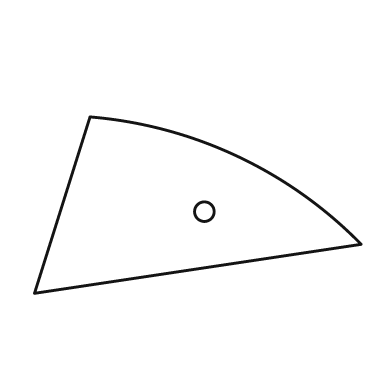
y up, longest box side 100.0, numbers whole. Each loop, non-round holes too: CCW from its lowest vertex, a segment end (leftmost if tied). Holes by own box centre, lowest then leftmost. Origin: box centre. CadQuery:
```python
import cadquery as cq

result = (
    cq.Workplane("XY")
    .moveTo(-50.0, -27.0)
    .lineTo(50.0, -12.0)
    .threePointArc((12.0, 15.0), (-33.0, 27.0))
    .close()
    .moveTo(2.0, -2.0)
    .circle(3.0)
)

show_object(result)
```